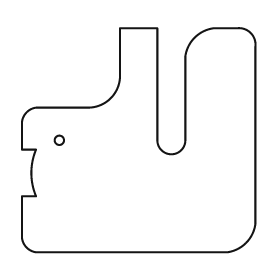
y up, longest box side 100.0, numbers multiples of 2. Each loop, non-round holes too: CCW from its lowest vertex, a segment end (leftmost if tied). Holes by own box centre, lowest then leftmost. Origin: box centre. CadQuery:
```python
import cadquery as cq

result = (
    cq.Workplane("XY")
    .moveTo(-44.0, -48.0)
    .lineTo(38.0, -48.0)
    .threePointArc((46.0, -44.0), (50.0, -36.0))
    .lineTo(50.0, 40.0)
    .threePointArc((48.0, 46.0), (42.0, 48.0))
    .lineTo(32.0, 48.0)
    .threePointArc((24.0, 44.0), (20.0, 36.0))
    .lineTo(20.0, 0.0)
    .threePointArc((14.0, -6.0), (8.0, 0.0))
    .lineTo(8.0, 48.0)
    .lineTo(-8.0, 48.0)
    .lineTo(-8.0, 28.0)
    .threePointArc((-12.0, 18.0), (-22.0, 14.0))
    .lineTo(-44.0, 14.0)
    .threePointArc((-48.0, 12.0), (-50.0, 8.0))
    .lineTo(-50.0, -4.0)
    .lineTo(-44.0, -4.0)
    .threePointArc((-46.0, -14.0), (-44.0, -24.0))
    .lineTo(-50.0, -24.0)
    .lineTo(-50.0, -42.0)
    .threePointArc((-48.0, -46.0), (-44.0, -48.0))
    .close()
    .moveTo(-34.0, 0.0)
    .circle(2.0)
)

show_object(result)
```